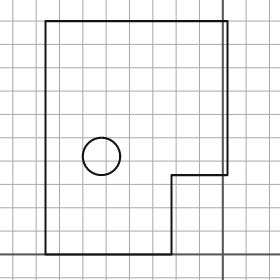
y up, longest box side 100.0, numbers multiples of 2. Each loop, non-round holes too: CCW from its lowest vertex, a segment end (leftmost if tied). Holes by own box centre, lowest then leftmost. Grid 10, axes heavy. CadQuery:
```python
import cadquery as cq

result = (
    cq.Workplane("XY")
    .moveTo(-76.0, 0.0)
    .lineTo(-22.0, 0.0)
    .lineTo(-22.0, 34.0)
    .lineTo(2.0, 34.0)
    .lineTo(2.0, 100.0)
    .lineTo(-76.0, 100.0)
    .close()
    .moveTo(-52.0, 42.0)
    .circle(8.0)
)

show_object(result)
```